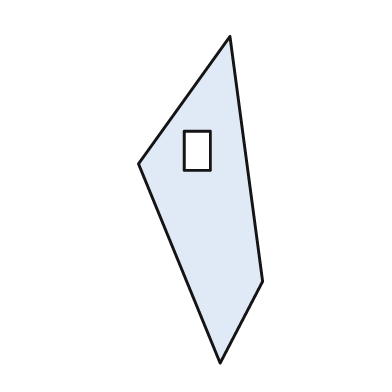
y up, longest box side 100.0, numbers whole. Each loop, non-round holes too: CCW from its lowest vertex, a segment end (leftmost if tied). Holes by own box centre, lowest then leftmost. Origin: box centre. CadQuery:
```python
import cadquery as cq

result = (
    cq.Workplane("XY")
    .moveTo(6.0, -50.0)
    .lineTo(19.0, -25.0)
    .lineTo(9.0, 50.0)
    .lineTo(-19.0, 11.0)
    .close()
    .moveTo(-5.0, 9.0)
    .lineTo(3.0, 9.0)
    .lineTo(3.0, 21.0)
    .lineTo(-5.0, 21.0)
    .close()
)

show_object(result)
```